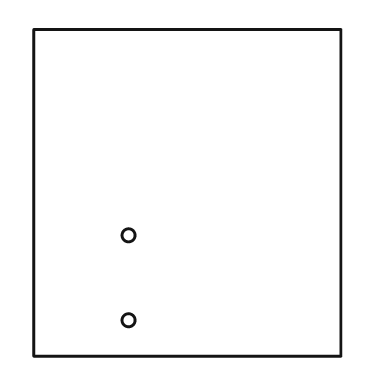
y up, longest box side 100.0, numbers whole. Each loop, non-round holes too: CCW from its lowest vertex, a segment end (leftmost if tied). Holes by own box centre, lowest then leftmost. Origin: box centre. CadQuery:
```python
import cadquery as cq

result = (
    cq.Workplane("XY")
    .moveTo(-47.0, -50.0)
    .lineTo(47.0, -50.0)
    .lineTo(47.0, 50.0)
    .lineTo(-47.0, 50.0)
    .close()
    .moveTo(-18.0, -39.0)
    .circle(2.0)
    .moveTo(-18.0, -13.0)
    .circle(2.0)
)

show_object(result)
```